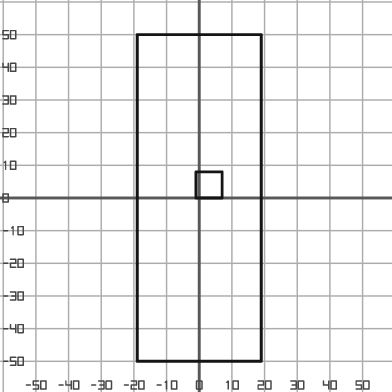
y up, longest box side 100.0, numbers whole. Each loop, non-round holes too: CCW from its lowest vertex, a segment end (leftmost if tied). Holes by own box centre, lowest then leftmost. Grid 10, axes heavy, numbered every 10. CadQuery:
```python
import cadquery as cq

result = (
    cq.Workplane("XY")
    .moveTo(-19.0, -50.0)
    .lineTo(19.0, -50.0)
    .lineTo(19.0, 50.0)
    .lineTo(-19.0, 50.0)
    .close()
    .moveTo(-1.0, 0.0)
    .lineTo(7.0, 0.0)
    .lineTo(7.0, 8.0)
    .lineTo(-1.0, 8.0)
    .close()
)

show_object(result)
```